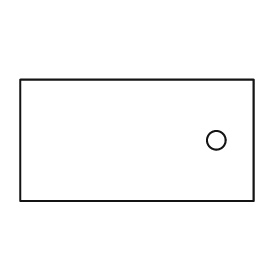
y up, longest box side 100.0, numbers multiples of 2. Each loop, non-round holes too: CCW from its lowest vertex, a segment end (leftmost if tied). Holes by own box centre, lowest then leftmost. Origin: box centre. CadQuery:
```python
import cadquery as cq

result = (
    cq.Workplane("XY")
    .moveTo(-50.0, -26.0)
    .lineTo(50.0, -26.0)
    .lineTo(50.0, 26.0)
    .lineTo(-50.0, 26.0)
    .close()
    .moveTo(34.0, 0.0)
    .circle(4.0)
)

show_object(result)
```